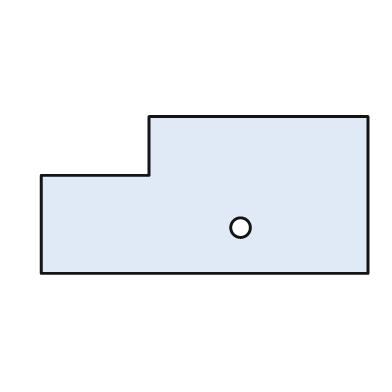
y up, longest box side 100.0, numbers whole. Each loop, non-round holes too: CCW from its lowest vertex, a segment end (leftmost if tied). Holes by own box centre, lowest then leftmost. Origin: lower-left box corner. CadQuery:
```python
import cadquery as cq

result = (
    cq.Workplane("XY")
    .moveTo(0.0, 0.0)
    .lineTo(100.0, 0.0)
    .lineTo(100.0, 48.0)
    .lineTo(33.0, 48.0)
    .lineTo(33.0, 30.0)
    .lineTo(0.0, 30.0)
    .close()
    .moveTo(61.0, 14.0)
    .circle(3.0)
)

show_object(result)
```